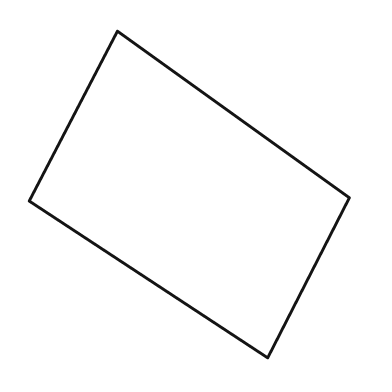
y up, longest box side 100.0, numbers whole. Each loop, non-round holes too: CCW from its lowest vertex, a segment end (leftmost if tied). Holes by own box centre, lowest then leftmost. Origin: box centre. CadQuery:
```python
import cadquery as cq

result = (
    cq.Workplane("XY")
    .moveTo(24.0, -50.0)
    .lineTo(49.0, -1.0)
    .lineTo(-22.0, 50.0)
    .lineTo(-49.0, -2.0)
    .close()
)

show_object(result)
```